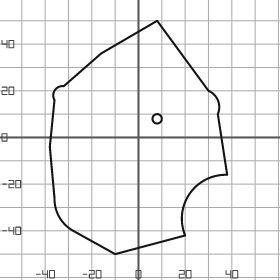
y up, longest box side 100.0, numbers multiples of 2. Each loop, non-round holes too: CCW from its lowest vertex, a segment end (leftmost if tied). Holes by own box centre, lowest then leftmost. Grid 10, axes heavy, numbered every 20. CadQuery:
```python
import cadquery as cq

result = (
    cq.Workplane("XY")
    .moveTo(-10.0, -50.0)
    .lineTo(20.0, -42.0)
    .threePointArc((22.0, -24.0), (38.0, -16.0))
    .lineTo(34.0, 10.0)
    .threePointArc((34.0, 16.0), (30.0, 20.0))
    .lineTo(8.0, 50.0)
    .lineTo(-16.0, 36.0)
    .lineTo(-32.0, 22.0)
    .threePointArc((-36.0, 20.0), (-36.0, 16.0))
    .lineTo(-38.0, -4.0)
    .lineTo(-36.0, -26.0)
    .threePointArc((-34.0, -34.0), (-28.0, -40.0))
    .close()
    .moveTo(8.0, 8.0)
    .circle(2.0)
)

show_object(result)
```